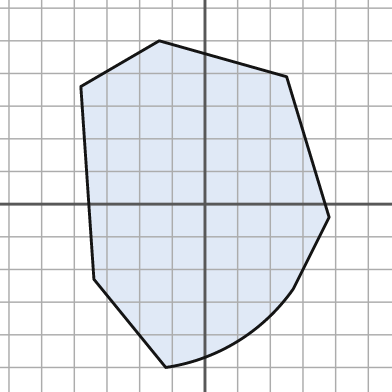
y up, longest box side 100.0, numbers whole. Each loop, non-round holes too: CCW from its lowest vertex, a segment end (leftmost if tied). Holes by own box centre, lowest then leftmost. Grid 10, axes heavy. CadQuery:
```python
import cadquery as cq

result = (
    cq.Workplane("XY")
    .moveTo(-12.0, -50.0)
    .threePointArc((10.0, -42.0), (27.0, -26.0))
    .lineTo(38.0, -4.0)
    .lineTo(25.0, 39.0)
    .lineTo(-14.0, 50.0)
    .lineTo(-38.0, 36.0)
    .lineTo(-34.0, -23.0)
    .close()
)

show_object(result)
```